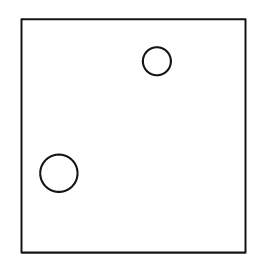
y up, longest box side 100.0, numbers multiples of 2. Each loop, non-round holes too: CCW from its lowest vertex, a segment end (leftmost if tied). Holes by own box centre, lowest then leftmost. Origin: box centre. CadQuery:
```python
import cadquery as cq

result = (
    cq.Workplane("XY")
    .moveTo(-48.0, -50.0)
    .lineTo(48.0, -50.0)
    .lineTo(48.0, 50.0)
    .lineTo(-48.0, 50.0)
    .close()
    .moveTo(-32.0, -16.0)
    .circle(8.0)
    .moveTo(10.0, 32.0)
    .circle(6.0)
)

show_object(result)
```